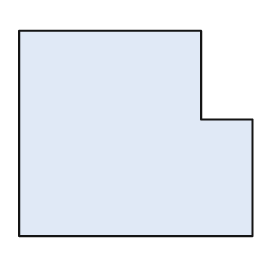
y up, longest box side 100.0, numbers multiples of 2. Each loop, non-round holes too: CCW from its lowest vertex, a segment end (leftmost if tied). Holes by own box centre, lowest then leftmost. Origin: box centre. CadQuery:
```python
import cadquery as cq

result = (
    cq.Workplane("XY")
    .moveTo(-50.0, -44.0)
    .lineTo(50.0, -44.0)
    .lineTo(50.0, 6.0)
    .lineTo(28.0, 6.0)
    .lineTo(28.0, 44.0)
    .lineTo(-50.0, 44.0)
    .close()
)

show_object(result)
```